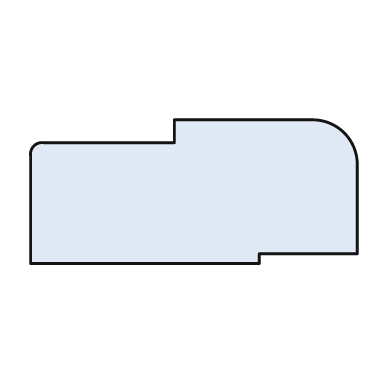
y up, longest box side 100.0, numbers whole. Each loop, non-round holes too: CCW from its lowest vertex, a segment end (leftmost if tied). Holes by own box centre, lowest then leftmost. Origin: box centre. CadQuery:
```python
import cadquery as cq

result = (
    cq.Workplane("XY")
    .moveTo(-50.0, -22.0)
    .lineTo(20.0, -22.0)
    .lineTo(20.0, -19.0)
    .lineTo(50.0, -19.0)
    .lineTo(50.0, 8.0)
    .threePointArc((46.0, 18.0), (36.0, 22.0))
    .lineTo(-6.0, 22.0)
    .lineTo(-6.0, 15.0)
    .lineTo(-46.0, 15.0)
    .threePointArc((-49.0, 14.0), (-50.0, 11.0))
    .close()
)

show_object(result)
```